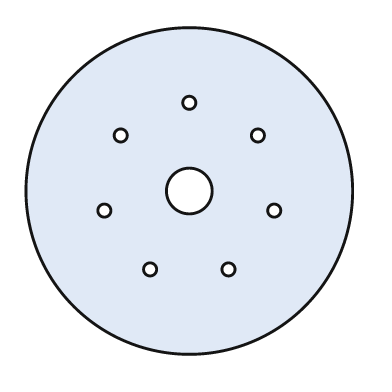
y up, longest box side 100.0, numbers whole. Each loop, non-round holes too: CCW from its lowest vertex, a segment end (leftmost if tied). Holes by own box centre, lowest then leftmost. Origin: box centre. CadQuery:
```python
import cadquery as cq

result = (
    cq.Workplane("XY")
    .moveTo(0.0, 0.0)
    .circle(50.0)
    .moveTo(-12.0, -24.0)
    .circle(2.0)
    .moveTo(12.0, -24.0)
    .circle(2.0)
    .moveTo(-26.0, -6.0)
    .circle(2.0)
    .moveTo(26.0, -6.0)
    .circle(2.0)
    .moveTo(0.0, 0.0)
    .circle(7.0)
    .moveTo(-21.0, 17.0)
    .circle(2.0)
    .moveTo(21.0, 17.0)
    .circle(2.0)
    .moveTo(0.0, 27.0)
    .circle(2.0)
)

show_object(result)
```